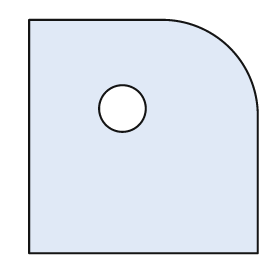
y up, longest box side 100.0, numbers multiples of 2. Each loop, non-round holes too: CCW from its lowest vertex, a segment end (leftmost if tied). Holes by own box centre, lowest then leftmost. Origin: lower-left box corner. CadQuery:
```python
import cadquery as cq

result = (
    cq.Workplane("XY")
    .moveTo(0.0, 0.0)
    .lineTo(98.0, 0.0)
    .lineTo(98.0, 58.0)
    .threePointArc((86.0, 88.0), (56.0, 100.0))
    .lineTo(0.0, 100.0)
    .close()
    .moveTo(40.0, 62.0)
    .circle(10.0)
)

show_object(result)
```